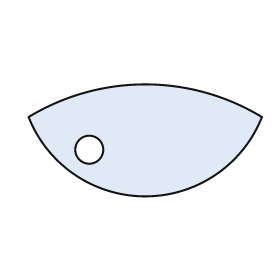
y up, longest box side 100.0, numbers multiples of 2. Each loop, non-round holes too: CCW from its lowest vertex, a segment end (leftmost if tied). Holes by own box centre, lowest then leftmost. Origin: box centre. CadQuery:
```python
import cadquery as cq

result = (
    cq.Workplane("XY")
    .moveTo(-50.0, 10.0)
    .threePointArc((0.0, -24.0), (50.0, 10.0))
    .threePointArc((0.0, 24.0), (-50.0, 10.0))
    .close()
    .moveTo(-24.0, -4.0)
    .circle(6.0)
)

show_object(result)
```